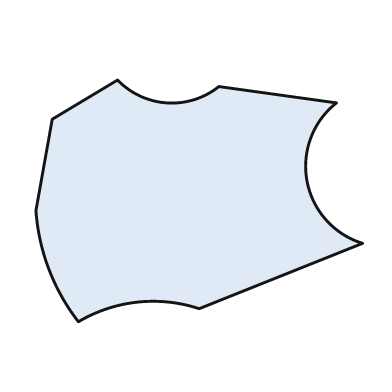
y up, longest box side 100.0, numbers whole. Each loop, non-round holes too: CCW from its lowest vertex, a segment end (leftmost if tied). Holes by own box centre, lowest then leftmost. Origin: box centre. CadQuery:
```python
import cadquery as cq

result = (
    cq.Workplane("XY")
    .moveTo(-37.0, -37.0)
    .threePointArc((-19.0, -31.0), (0.0, -33.0))
    .lineTo(50.0, -13.0)
    .threePointArc((33.0, 6.0), (42.0, 30.0))
    .lineTo(6.0, 35.0)
    .threePointArc((-10.0, 30.0), (-25.0, 37.0))
    .lineTo(-45.0, 25.0)
    .lineTo(-50.0, -3.0)
    .threePointArc((-46.0, -21.0), (-37.0, -37.0))
    .close()
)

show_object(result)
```